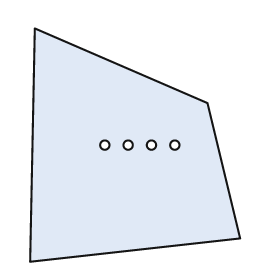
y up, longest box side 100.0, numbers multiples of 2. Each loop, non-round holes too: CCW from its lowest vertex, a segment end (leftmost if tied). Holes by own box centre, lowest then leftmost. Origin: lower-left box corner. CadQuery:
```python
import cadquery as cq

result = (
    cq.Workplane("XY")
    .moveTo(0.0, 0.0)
    .lineTo(90.0, 10.0)
    .lineTo(76.0, 68.0)
    .lineTo(2.0, 100.0)
    .close()
    .moveTo(32.0, 50.0)
    .circle(2.0)
    .moveTo(42.0, 50.0)
    .circle(2.0)
    .moveTo(52.0, 50.0)
    .circle(2.0)
    .moveTo(62.0, 50.0)
    .circle(2.0)
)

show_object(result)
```